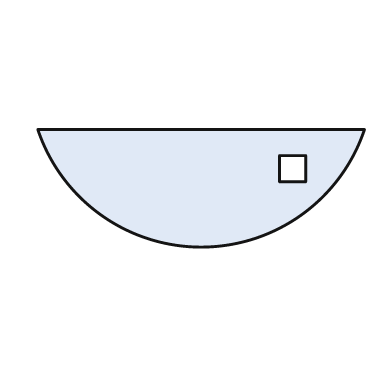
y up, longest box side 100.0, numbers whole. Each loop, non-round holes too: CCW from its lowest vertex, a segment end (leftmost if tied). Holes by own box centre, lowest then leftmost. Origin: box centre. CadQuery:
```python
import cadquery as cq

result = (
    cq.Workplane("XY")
    .moveTo(-50.0, 18.0)
    .threePointArc((0.0, -18.0), (50.0, 18.0))
    .close()
    .moveTo(24.0, 2.0)
    .lineTo(32.0, 2.0)
    .lineTo(32.0, 10.0)
    .lineTo(24.0, 10.0)
    .close()
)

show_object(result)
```